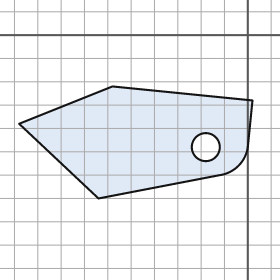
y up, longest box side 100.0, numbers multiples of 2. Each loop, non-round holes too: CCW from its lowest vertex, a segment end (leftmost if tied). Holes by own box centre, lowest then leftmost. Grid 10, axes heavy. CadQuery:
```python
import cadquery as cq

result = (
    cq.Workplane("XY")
    .moveTo(-64.0, -70.0)
    .lineTo(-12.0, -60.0)
    .threePointArc((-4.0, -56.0), (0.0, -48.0))
    .lineTo(2.0, -28.0)
    .lineTo(-58.0, -22.0)
    .lineTo(-98.0, -38.0)
    .close()
    .moveTo(-18.0, -48.0)
    .circle(6.0)
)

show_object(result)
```